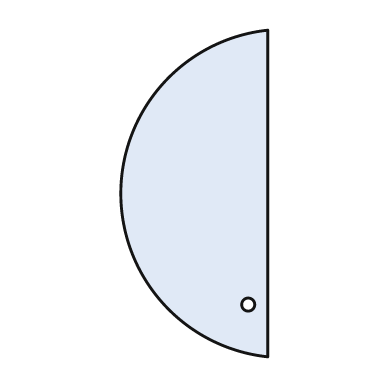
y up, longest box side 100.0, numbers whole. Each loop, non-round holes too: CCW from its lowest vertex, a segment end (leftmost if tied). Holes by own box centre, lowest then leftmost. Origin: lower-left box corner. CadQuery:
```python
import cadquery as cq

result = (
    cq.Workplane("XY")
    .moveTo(45.0, 0.0)
    .lineTo(45.0, 100.0)
    .threePointArc((0.0, 50.0), (45.0, 0.0))
    .close()
    .moveTo(39.0, 16.0)
    .circle(2.0)
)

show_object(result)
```